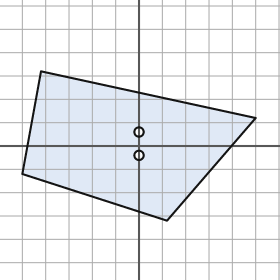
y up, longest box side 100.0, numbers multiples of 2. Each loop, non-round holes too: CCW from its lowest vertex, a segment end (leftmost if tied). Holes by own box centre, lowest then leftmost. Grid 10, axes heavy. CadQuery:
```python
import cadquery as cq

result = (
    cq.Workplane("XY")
    .moveTo(12.0, -32.0)
    .lineTo(50.0, 12.0)
    .lineTo(-42.0, 32.0)
    .lineTo(-50.0, -12.0)
    .close()
    .moveTo(0.0, -4.0)
    .circle(2.0)
    .moveTo(0.0, 6.0)
    .circle(2.0)
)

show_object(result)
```